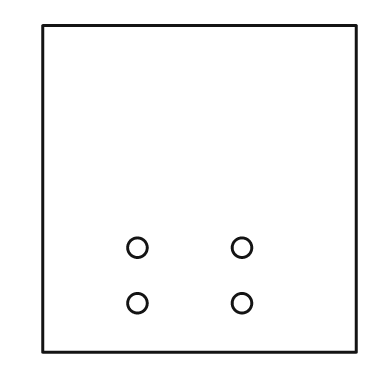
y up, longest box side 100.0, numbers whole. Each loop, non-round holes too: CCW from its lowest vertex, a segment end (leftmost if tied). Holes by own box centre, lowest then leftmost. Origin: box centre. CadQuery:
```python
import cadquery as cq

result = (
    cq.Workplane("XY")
    .moveTo(-48.0, -50.0)
    .lineTo(48.0, -50.0)
    .lineTo(48.0, 50.0)
    .lineTo(-48.0, 50.0)
    .close()
    .moveTo(-19.0, -35.0)
    .circle(3.0)
    .moveTo(13.0, -35.0)
    .circle(3.0)
    .moveTo(-19.0, -18.0)
    .circle(3.0)
    .moveTo(13.0, -18.0)
    .circle(3.0)
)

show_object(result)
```